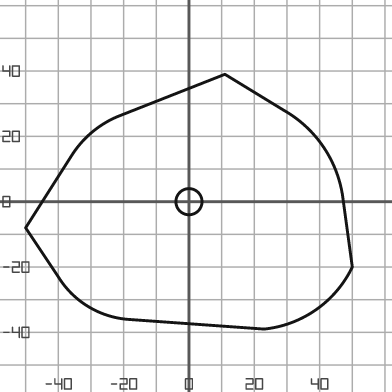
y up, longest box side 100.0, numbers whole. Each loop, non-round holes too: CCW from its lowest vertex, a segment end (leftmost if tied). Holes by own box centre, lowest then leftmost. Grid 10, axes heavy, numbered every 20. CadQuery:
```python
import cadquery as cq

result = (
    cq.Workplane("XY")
    .moveTo(23.0, -39.0)
    .threePointArc((39.0, -33.0), (50.0, -20.0))
    .lineTo(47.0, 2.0)
    .threePointArc((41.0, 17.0), (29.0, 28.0))
    .lineTo(11.0, 39.0)
    .lineTo(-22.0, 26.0)
    .threePointArc((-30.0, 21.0), (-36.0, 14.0))
    .lineTo(-50.0, -8.0)
    .lineTo(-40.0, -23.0)
    .threePointArc((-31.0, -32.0), (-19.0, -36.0))
    .close()
    .moveTo(0.0, 0.0)
    .circle(4.0)
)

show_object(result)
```